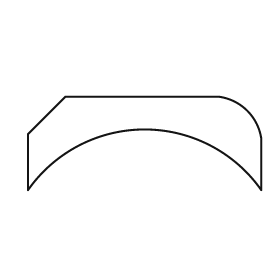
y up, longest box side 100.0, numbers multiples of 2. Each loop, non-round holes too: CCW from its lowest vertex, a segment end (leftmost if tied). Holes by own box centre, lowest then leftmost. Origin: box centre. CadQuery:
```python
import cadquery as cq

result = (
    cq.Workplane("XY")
    .moveTo(-50.0, -20.0)
    .threePointArc((0.0, 6.0), (50.0, -20.0))
    .lineTo(50.0, 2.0)
    .threePointArc((44.0, 14.0), (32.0, 20.0))
    .lineTo(-34.0, 20.0)
    .lineTo(-50.0, 4.0)
    .close()
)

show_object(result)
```